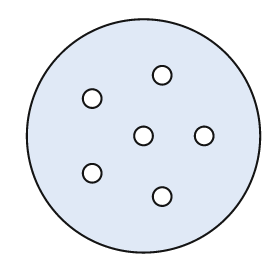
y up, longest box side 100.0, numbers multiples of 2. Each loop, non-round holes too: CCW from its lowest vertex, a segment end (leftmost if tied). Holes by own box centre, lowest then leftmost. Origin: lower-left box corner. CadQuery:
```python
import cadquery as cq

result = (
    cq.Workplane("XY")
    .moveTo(50.0, 50.0)
    .circle(50.0)
    .moveTo(58.0, 24.0)
    .circle(4.0)
    .moveTo(28.0, 34.0)
    .circle(4.0)
    .moveTo(50.0, 50.0)
    .circle(4.0)
    .moveTo(76.0, 50.0)
    .circle(4.0)
    .moveTo(28.0, 66.0)
    .circle(4.0)
    .moveTo(58.0, 76.0)
    .circle(4.0)
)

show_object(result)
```